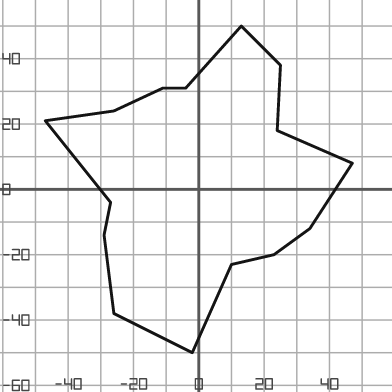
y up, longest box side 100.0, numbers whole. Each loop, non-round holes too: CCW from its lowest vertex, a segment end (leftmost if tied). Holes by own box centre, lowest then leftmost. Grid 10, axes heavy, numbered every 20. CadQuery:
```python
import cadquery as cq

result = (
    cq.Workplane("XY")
    .moveTo(-2.0, -50.0)
    .lineTo(10.0, -23.0)
    .lineTo(23.0, -20.0)
    .lineTo(34.0, -12.0)
    .lineTo(47.0, 8.0)
    .lineTo(24.0, 18.0)
    .lineTo(25.0, 38.0)
    .lineTo(13.0, 50.0)
    .lineTo(-4.0, 31.0)
    .lineTo(-11.0, 31.0)
    .lineTo(-26.0, 24.0)
    .lineTo(-47.0, 21.0)
    .lineTo(-27.0, -4.0)
    .lineTo(-29.0, -14.0)
    .lineTo(-26.0, -38.0)
    .close()
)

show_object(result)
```